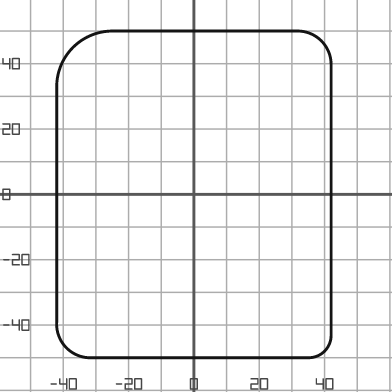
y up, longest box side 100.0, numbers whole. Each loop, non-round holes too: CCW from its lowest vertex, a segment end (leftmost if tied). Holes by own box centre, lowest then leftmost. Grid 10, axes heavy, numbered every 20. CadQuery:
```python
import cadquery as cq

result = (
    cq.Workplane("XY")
    .moveTo(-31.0, -50.0)
    .lineTo(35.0, -50.0)
    .threePointArc((40.0, -48.0), (42.0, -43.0))
    .lineTo(42.0, 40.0)
    .threePointArc((39.0, 47.0), (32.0, 50.0))
    .lineTo(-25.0, 50.0)
    .threePointArc((-37.0, 45.0), (-42.0, 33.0))
    .lineTo(-42.0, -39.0)
    .threePointArc((-39.0, -47.0), (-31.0, -50.0))
    .close()
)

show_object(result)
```